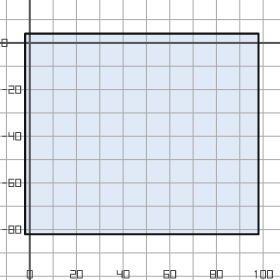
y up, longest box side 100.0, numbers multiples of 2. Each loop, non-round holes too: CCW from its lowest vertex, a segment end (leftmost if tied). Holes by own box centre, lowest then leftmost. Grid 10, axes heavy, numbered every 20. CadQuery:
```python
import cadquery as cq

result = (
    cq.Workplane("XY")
    .moveTo(-2.0, -82.0)
    .lineTo(98.0, -82.0)
    .lineTo(98.0, 4.0)
    .lineTo(-2.0, 4.0)
    .close()
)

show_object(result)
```